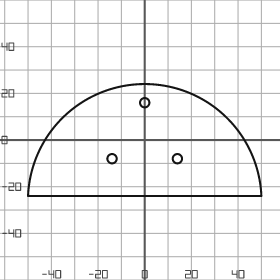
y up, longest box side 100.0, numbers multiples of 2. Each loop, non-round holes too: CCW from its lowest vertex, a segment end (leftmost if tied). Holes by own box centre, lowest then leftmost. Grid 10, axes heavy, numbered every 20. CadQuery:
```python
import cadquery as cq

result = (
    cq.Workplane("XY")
    .moveTo(-50.0, -24.0)
    .lineTo(50.0, -24.0)
    .threePointArc((0.0, 24.0), (-50.0, -24.0))
    .close()
    .moveTo(-14.0, -8.0)
    .circle(2.0)
    .moveTo(14.0, -8.0)
    .circle(2.0)
    .moveTo(0.0, 16.0)
    .circle(2.0)
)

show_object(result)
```